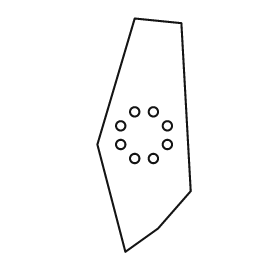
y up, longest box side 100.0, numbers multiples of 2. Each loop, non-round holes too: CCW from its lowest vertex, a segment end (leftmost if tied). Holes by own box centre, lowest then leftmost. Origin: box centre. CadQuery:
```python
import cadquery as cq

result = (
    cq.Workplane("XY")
    .moveTo(-8.0, -50.0)
    .lineTo(6.0, -40.0)
    .lineTo(20.0, -24.0)
    .lineTo(16.0, 48.0)
    .lineTo(-4.0, 50.0)
    .lineTo(-20.0, -4.0)
    .close()
    .moveTo(-4.0, -10.0)
    .circle(2.0)
    .moveTo(4.0, -10.0)
    .circle(2.0)
    .moveTo(-10.0, -4.0)
    .circle(2.0)
    .moveTo(10.0, -4.0)
    .circle(2.0)
    .moveTo(-10.0, 4.0)
    .circle(2.0)
    .moveTo(10.0, 4.0)
    .circle(2.0)
    .moveTo(-4.0, 10.0)
    .circle(2.0)
    .moveTo(4.0, 10.0)
    .circle(2.0)
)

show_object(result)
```